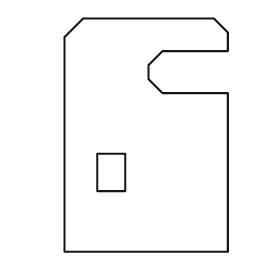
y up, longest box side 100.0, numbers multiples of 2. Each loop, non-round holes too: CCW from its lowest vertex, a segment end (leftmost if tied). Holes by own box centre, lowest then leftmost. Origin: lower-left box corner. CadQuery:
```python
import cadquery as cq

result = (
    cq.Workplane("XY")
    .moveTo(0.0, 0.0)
    .lineTo(70.0, 0.0)
    .lineTo(70.0, 68.0)
    .lineTo(42.0, 68.0)
    .lineTo(36.0, 74.0)
    .lineTo(36.0, 80.0)
    .lineTo(42.0, 86.0)
    .lineTo(70.0, 86.0)
    .lineTo(70.0, 94.0)
    .lineTo(64.0, 100.0)
    .lineTo(8.0, 100.0)
    .lineTo(0.0, 92.0)
    .close()
    .moveTo(14.0, 26.0)
    .lineTo(26.0, 26.0)
    .lineTo(26.0, 42.0)
    .lineTo(14.0, 42.0)
    .close()
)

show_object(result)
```